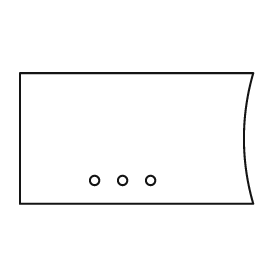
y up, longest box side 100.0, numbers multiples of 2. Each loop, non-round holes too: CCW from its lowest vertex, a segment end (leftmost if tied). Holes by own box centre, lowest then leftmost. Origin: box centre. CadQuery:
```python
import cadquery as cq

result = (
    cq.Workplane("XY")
    .moveTo(-50.0, -28.0)
    .lineTo(50.0, -28.0)
    .threePointArc((46.0, 0.0), (50.0, 28.0))
    .lineTo(-50.0, 28.0)
    .close()
    .moveTo(-18.0, -18.0)
    .circle(2.0)
    .moveTo(-6.0, -18.0)
    .circle(2.0)
    .moveTo(6.0, -18.0)
    .circle(2.0)
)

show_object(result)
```